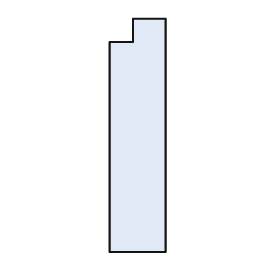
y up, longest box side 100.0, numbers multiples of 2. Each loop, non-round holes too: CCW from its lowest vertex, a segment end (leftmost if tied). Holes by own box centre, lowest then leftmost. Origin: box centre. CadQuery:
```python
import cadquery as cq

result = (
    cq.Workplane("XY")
    .moveTo(-12.0, -50.0)
    .lineTo(12.0, -50.0)
    .lineTo(12.0, 50.0)
    .lineTo(-2.0, 50.0)
    .lineTo(-2.0, 40.0)
    .lineTo(-12.0, 40.0)
    .close()
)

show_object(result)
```